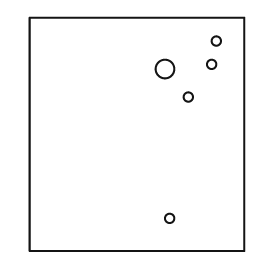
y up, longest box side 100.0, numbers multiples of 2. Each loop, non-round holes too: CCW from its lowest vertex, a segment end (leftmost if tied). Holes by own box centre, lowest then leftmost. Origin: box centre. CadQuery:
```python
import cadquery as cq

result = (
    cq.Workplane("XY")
    .moveTo(-46.0, -50.0)
    .lineTo(46.0, -50.0)
    .lineTo(46.0, 50.0)
    .lineTo(-46.0, 50.0)
    .close()
    .moveTo(14.0, -36.0)
    .circle(2.0)
    .moveTo(22.0, 16.0)
    .circle(2.0)
    .moveTo(12.0, 28.0)
    .circle(4.0)
    .moveTo(32.0, 30.0)
    .circle(2.0)
    .moveTo(34.0, 40.0)
    .circle(2.0)
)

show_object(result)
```